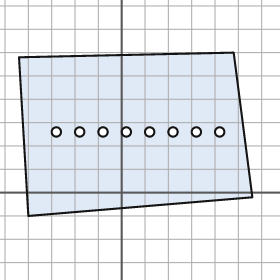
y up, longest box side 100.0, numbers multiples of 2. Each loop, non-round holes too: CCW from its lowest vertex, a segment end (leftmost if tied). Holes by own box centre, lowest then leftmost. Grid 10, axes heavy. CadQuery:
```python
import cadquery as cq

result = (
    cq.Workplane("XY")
    .moveTo(-40.0, -10.0)
    .lineTo(56.0, -2.0)
    .lineTo(48.0, 60.0)
    .lineTo(-44.0, 58.0)
    .close()
    .moveTo(-28.0, 26.0)
    .circle(2.0)
    .moveTo(-18.0, 26.0)
    .circle(2.0)
    .moveTo(-8.0, 26.0)
    .circle(2.0)
    .moveTo(2.0, 26.0)
    .circle(2.0)
    .moveTo(12.0, 26.0)
    .circle(2.0)
    .moveTo(22.0, 26.0)
    .circle(2.0)
    .moveTo(32.0, 26.0)
    .circle(2.0)
    .moveTo(42.0, 26.0)
    .circle(2.0)
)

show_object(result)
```